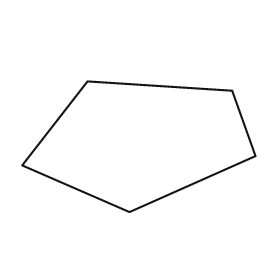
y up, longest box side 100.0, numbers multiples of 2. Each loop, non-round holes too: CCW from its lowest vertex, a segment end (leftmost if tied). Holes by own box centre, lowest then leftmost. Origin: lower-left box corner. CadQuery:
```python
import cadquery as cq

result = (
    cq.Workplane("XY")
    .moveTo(46.0, 0.0)
    .lineTo(100.0, 24.0)
    .lineTo(90.0, 52.0)
    .lineTo(28.0, 56.0)
    .lineTo(0.0, 20.0)
    .close()
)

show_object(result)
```